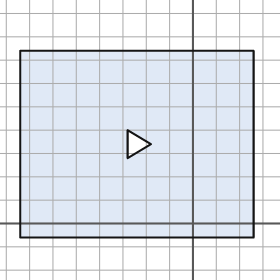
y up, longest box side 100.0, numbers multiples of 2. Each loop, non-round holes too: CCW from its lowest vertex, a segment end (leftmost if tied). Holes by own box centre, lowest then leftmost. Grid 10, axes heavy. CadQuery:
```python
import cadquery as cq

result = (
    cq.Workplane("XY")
    .moveTo(-74.0, -6.0)
    .lineTo(26.0, -6.0)
    .lineTo(26.0, 74.0)
    .lineTo(-74.0, 74.0)
    .close()
    .moveTo(-28.0, 28.0)
    .lineTo(-18.0, 34.0)
    .lineTo(-28.0, 40.0)
    .close()
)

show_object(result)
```